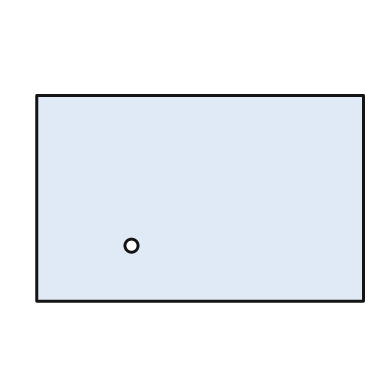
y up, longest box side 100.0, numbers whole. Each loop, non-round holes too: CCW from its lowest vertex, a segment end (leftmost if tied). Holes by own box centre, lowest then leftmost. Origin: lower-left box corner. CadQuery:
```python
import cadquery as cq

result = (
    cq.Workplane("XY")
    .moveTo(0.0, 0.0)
    .lineTo(100.0, 0.0)
    .lineTo(100.0, 63.0)
    .lineTo(0.0, 63.0)
    .close()
    .moveTo(29.0, 17.0)
    .circle(2.0)
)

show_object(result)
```